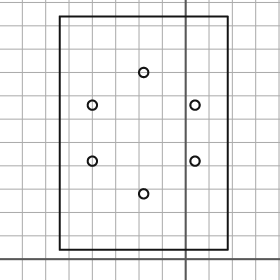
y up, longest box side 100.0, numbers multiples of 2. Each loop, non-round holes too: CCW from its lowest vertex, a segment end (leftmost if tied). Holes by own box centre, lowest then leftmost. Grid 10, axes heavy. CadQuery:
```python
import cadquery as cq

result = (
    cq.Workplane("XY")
    .moveTo(-54.0, 4.0)
    .lineTo(18.0, 4.0)
    .lineTo(18.0, 104.0)
    .lineTo(-54.0, 104.0)
    .close()
    .moveTo(-18.0, 28.0)
    .circle(2.0)
    .moveTo(-40.0, 42.0)
    .circle(2.0)
    .moveTo(4.0, 42.0)
    .circle(2.0)
    .moveTo(-40.0, 66.0)
    .circle(2.0)
    .moveTo(4.0, 66.0)
    .circle(2.0)
    .moveTo(-18.0, 80.0)
    .circle(2.0)
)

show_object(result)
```